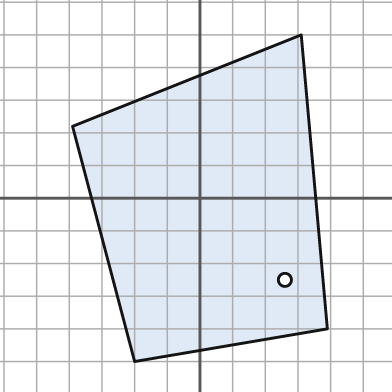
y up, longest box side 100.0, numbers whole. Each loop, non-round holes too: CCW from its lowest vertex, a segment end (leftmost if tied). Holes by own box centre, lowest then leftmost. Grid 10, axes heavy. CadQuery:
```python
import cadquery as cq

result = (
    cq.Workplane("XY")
    .moveTo(-20.0, -50.0)
    .lineTo(39.0, -40.0)
    .lineTo(31.0, 50.0)
    .lineTo(-39.0, 22.0)
    .close()
    .moveTo(26.0, -25.0)
    .circle(2.0)
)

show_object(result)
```